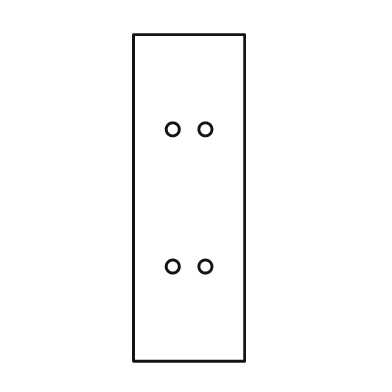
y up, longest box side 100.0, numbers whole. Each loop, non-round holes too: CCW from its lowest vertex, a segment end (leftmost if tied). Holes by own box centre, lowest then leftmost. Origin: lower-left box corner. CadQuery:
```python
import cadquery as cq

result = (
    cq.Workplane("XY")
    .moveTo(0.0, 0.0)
    .lineTo(34.0, 0.0)
    .lineTo(34.0, 100.0)
    .lineTo(0.0, 100.0)
    .close()
    .moveTo(12.0, 29.0)
    .circle(2.0)
    .moveTo(22.0, 29.0)
    .circle(2.0)
    .moveTo(12.0, 71.0)
    .circle(2.0)
    .moveTo(22.0, 71.0)
    .circle(2.0)
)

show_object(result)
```